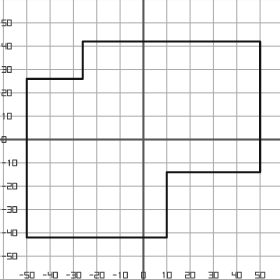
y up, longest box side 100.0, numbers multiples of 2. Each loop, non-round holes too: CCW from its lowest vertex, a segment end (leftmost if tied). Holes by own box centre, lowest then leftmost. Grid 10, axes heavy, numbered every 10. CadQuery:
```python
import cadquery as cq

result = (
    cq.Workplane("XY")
    .moveTo(-50.0, -42.0)
    .lineTo(10.0, -42.0)
    .lineTo(10.0, -14.0)
    .lineTo(50.0, -14.0)
    .lineTo(50.0, 42.0)
    .lineTo(-26.0, 42.0)
    .lineTo(-26.0, 26.0)
    .lineTo(-50.0, 26.0)
    .close()
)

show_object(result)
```